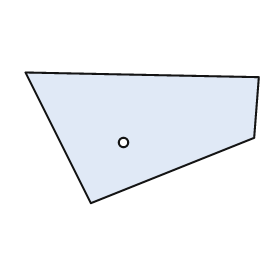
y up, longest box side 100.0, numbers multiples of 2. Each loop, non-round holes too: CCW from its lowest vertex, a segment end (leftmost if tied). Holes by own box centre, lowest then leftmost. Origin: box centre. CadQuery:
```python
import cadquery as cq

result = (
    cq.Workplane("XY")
    .moveTo(-22.0, -28.0)
    .lineTo(48.0, 0.0)
    .lineTo(50.0, 26.0)
    .lineTo(-50.0, 28.0)
    .close()
    .moveTo(-8.0, -2.0)
    .circle(2.0)
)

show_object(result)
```